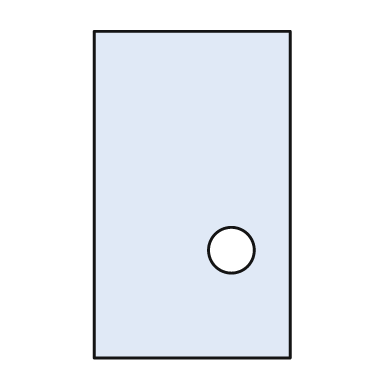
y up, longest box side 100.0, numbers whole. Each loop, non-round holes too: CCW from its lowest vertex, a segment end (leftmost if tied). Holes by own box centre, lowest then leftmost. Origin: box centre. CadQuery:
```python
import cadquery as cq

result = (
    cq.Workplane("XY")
    .moveTo(-30.0, -50.0)
    .lineTo(30.0, -50.0)
    .lineTo(30.0, 50.0)
    .lineTo(-30.0, 50.0)
    .close()
    .moveTo(12.0, -17.0)
    .circle(7.0)
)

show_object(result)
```